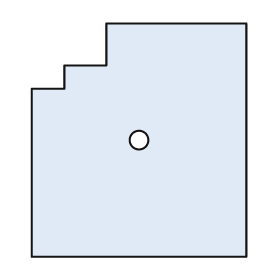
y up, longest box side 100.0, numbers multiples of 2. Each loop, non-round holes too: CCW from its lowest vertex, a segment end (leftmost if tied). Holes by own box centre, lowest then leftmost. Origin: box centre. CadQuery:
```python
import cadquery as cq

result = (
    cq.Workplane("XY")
    .moveTo(-46.0, -50.0)
    .lineTo(46.0, -50.0)
    .lineTo(46.0, 50.0)
    .lineTo(-14.0, 50.0)
    .lineTo(-14.0, 32.0)
    .lineTo(-32.0, 32.0)
    .lineTo(-32.0, 22.0)
    .lineTo(-46.0, 22.0)
    .close()
    .moveTo(0.0, 0.0)
    .circle(4.0)
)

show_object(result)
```